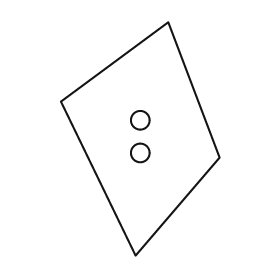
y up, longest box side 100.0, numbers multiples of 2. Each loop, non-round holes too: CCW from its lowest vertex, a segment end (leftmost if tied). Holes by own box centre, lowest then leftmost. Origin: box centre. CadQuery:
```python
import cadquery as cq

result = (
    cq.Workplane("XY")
    .moveTo(-2.0, -50.0)
    .lineTo(34.0, -8.0)
    .lineTo(12.0, 50.0)
    .lineTo(-34.0, 16.0)
    .close()
    .moveTo(0.0, -6.0)
    .circle(4.0)
    .moveTo(0.0, 8.0)
    .circle(4.0)
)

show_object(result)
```